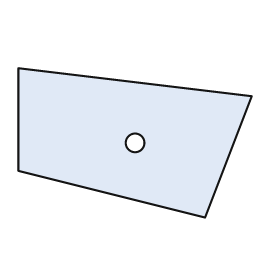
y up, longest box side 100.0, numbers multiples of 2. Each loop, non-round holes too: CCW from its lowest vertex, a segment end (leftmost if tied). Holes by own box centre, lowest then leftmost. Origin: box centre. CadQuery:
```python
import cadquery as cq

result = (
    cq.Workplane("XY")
    .moveTo(30.0, -32.0)
    .lineTo(50.0, 20.0)
    .lineTo(-50.0, 32.0)
    .lineTo(-50.0, -12.0)
    .close()
    .moveTo(0.0, 0.0)
    .circle(4.0)
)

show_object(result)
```